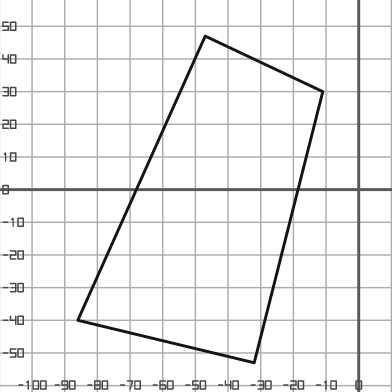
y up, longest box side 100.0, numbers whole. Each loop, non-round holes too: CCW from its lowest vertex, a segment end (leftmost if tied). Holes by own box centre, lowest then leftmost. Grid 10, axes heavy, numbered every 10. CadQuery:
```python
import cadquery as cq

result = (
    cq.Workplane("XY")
    .moveTo(-32.0, -53.0)
    .lineTo(-11.0, 30.0)
    .lineTo(-47.0, 47.0)
    .lineTo(-86.0, -40.0)
    .close()
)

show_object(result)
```